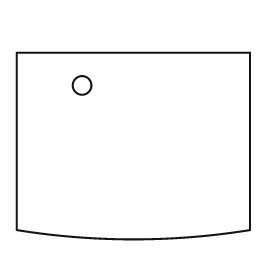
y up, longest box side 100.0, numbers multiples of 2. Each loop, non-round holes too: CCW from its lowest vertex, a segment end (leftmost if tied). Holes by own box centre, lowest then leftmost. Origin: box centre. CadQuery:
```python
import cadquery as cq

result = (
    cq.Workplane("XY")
    .moveTo(-50.0, -36.0)
    .threePointArc((0.0, -40.0), (50.0, -36.0))
    .lineTo(50.0, 40.0)
    .lineTo(-50.0, 40.0)
    .close()
    .moveTo(-22.0, 26.0)
    .circle(4.0)
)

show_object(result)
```